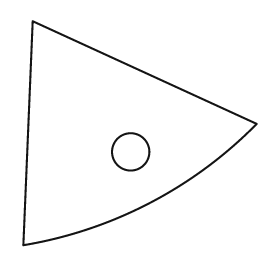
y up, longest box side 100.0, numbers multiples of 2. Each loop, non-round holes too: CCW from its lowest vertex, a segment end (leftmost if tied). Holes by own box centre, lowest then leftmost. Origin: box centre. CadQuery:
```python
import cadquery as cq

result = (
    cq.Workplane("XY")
    .moveTo(-50.0, -48.0)
    .threePointArc((4.0, -30.0), (50.0, 4.0))
    .lineTo(-46.0, 48.0)
    .close()
    .moveTo(-4.0, -8.0)
    .circle(8.0)
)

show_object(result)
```